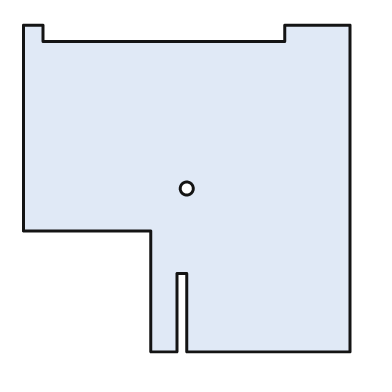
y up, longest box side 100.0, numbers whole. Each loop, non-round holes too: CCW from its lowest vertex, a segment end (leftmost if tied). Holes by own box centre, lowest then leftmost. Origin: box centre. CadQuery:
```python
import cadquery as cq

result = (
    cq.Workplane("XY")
    .moveTo(-11.0, -50.0)
    .lineTo(-3.0, -50.0)
    .lineTo(-3.0, -26.0)
    .lineTo(0.0, -26.0)
    .lineTo(0.0, -50.0)
    .lineTo(50.0, -50.0)
    .lineTo(50.0, 50.0)
    .lineTo(30.0, 50.0)
    .lineTo(30.0, 45.0)
    .lineTo(-44.0, 45.0)
    .lineTo(-44.0, 50.0)
    .lineTo(-50.0, 50.0)
    .lineTo(-50.0, -13.0)
    .lineTo(-11.0, -13.0)
    .close()
    .moveTo(0.0, 0.0)
    .circle(2.0)
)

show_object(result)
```